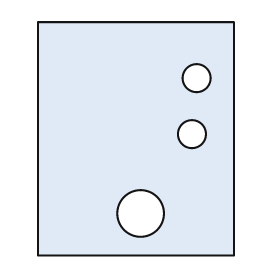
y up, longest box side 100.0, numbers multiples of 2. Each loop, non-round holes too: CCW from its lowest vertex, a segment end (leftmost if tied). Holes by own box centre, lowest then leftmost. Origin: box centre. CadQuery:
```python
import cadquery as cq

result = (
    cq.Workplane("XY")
    .moveTo(-42.0, -50.0)
    .lineTo(42.0, -50.0)
    .lineTo(42.0, 50.0)
    .lineTo(-42.0, 50.0)
    .close()
    .moveTo(2.0, -32.0)
    .circle(10.0)
    .moveTo(24.0, 2.0)
    .circle(6.0)
    .moveTo(26.0, 26.0)
    .circle(6.0)
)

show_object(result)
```